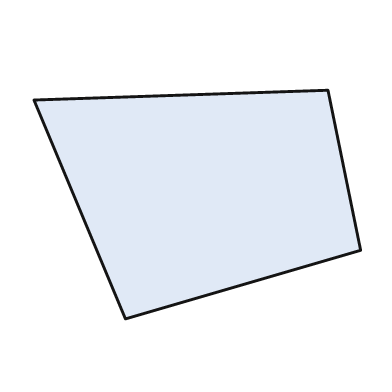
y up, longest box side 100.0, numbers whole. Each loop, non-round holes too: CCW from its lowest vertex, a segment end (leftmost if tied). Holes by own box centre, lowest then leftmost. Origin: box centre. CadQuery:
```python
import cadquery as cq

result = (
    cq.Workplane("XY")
    .moveTo(-22.0, -35.0)
    .lineTo(50.0, -14.0)
    .lineTo(40.0, 35.0)
    .lineTo(-50.0, 32.0)
    .close()
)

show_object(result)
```